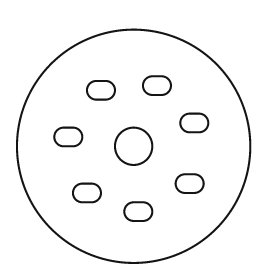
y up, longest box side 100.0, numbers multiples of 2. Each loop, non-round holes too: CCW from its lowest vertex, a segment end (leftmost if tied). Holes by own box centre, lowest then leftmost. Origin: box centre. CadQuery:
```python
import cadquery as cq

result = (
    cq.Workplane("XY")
    .moveTo(0.0, 0.0)
    .circle(50.0)
    .moveTo(0.0, -32.0)
    .lineTo(4.0, -32.0)
    .threePointArc((8.0, -28.0), (4.0, -24.0))
    .lineTo(0.0, -24.0)
    .threePointArc((-4.0, -28.0), (0.0, -32.0))
    .close()
    .moveTo(-22.0, -24.0)
    .lineTo(-18.0, -24.0)
    .threePointArc((-14.0, -20.0), (-18.0, -16.0))
    .lineTo(-22.0, -16.0)
    .threePointArc((-26.0, -20.0), (-22.0, -24.0))
    .close()
    .moveTo(22.0, -20.0)
    .lineTo(26.0, -20.0)
    .threePointArc((30.0, -16.0), (26.0, -12.0))
    .lineTo(22.0, -12.0)
    .threePointArc((18.0, -16.0), (22.0, -20.0))
    .close()
    .moveTo(0.0, 0.0)
    .circle(8.0)
    .moveTo(-30.0, 0.0)
    .lineTo(-26.0, 0.0)
    .threePointArc((-22.0, 4.0), (-26.0, 8.0))
    .lineTo(-30.0, 8.0)
    .threePointArc((-34.0, 4.0), (-30.0, 0.0))
    .close()
    .moveTo(24.0, 6.0)
    .lineTo(28.0, 6.0)
    .threePointArc((32.0, 10.0), (28.0, 14.0))
    .lineTo(24.0, 14.0)
    .threePointArc((20.0, 10.0), (24.0, 6.0))
    .close()
    .moveTo(-16.0, 20.0)
    .lineTo(-12.0, 20.0)
    .threePointArc((-8.0, 24.0), (-12.0, 28.0))
    .lineTo(-16.0, 28.0)
    .threePointArc((-20.0, 24.0), (-16.0, 20.0))
    .close()
    .moveTo(8.0, 22.0)
    .lineTo(12.0, 22.0)
    .threePointArc((16.0, 26.0), (12.0, 30.0))
    .lineTo(8.0, 30.0)
    .threePointArc((4.0, 26.0), (8.0, 22.0))
    .close()
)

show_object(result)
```